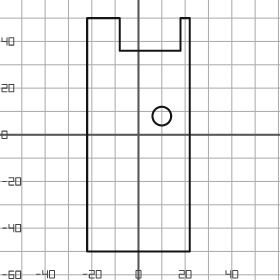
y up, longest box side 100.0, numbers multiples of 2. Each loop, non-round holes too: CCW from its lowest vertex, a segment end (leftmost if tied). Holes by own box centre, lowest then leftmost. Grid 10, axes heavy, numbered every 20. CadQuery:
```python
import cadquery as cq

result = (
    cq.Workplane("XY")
    .moveTo(-22.0, -50.0)
    .lineTo(22.0, -50.0)
    .lineTo(22.0, 50.0)
    .lineTo(18.0, 50.0)
    .lineTo(18.0, 36.0)
    .lineTo(-8.0, 36.0)
    .lineTo(-8.0, 50.0)
    .lineTo(-22.0, 50.0)
    .close()
    .moveTo(10.0, 8.0)
    .circle(4.0)
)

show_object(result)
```